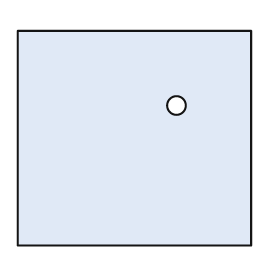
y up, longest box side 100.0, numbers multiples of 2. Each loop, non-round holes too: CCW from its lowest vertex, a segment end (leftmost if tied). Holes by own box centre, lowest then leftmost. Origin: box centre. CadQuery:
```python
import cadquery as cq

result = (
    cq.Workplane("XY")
    .moveTo(-50.0, -46.0)
    .lineTo(50.0, -46.0)
    .lineTo(50.0, 46.0)
    .lineTo(-50.0, 46.0)
    .close()
    .moveTo(18.0, 14.0)
    .circle(4.0)
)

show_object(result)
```